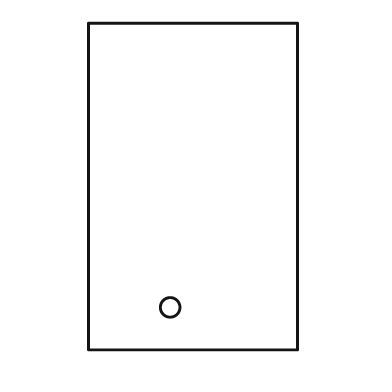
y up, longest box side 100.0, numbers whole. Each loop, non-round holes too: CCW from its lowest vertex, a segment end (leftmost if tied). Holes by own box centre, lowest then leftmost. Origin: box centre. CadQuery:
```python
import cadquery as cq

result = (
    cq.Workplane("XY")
    .moveTo(-32.0, -50.0)
    .lineTo(32.0, -50.0)
    .lineTo(32.0, 50.0)
    .lineTo(-32.0, 50.0)
    .close()
    .moveTo(-7.0, -37.0)
    .circle(3.0)
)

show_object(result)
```